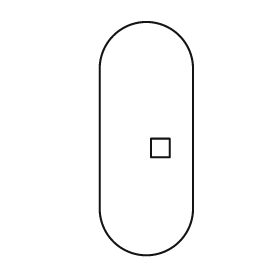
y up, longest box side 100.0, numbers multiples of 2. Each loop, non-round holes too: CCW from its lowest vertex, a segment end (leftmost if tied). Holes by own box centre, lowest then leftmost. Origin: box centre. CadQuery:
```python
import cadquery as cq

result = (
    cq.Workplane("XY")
    .moveTo(-20.0, -30.0)
    .threePointArc((0.0, -50.0), (20.0, -30.0))
    .lineTo(20.0, 30.0)
    .threePointArc((0.0, 50.0), (-20.0, 30.0))
    .close()
    .moveTo(2.0, -8.0)
    .lineTo(10.0, -8.0)
    .lineTo(10.0, 0.0)
    .lineTo(2.0, 0.0)
    .close()
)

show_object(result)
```